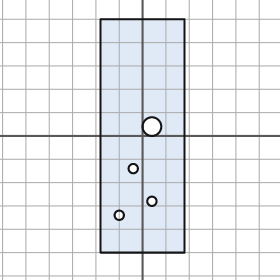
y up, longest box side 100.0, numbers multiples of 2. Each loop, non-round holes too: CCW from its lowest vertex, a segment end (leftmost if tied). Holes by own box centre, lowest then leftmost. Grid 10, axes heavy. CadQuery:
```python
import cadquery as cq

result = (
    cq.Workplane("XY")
    .moveTo(-18.0, -50.0)
    .lineTo(18.0, -50.0)
    .lineTo(18.0, 50.0)
    .lineTo(-18.0, 50.0)
    .close()
    .moveTo(-10.0, -34.0)
    .circle(2.0)
    .moveTo(4.0, -28.0)
    .circle(2.0)
    .moveTo(-4.0, -14.0)
    .circle(2.0)
    .moveTo(4.0, 4.0)
    .circle(4.0)
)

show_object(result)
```